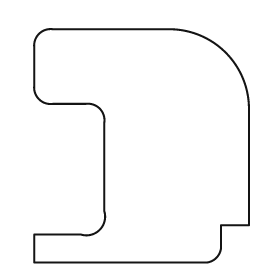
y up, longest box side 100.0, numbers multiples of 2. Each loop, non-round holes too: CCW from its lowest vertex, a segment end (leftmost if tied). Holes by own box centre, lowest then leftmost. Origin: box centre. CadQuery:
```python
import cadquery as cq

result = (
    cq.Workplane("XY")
    .moveTo(-46.0, -50.0)
    .lineTo(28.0, -50.0)
    .threePointArc((32.0, -48.0), (34.0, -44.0))
    .lineTo(34.0, -34.0)
    .lineTo(46.0, -34.0)
    .lineTo(46.0, 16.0)
    .threePointArc((36.0, 40.0), (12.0, 50.0))
    .lineTo(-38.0, 50.0)
    .threePointArc((-44.0, 48.0), (-46.0, 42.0))
    .lineTo(-46.0, 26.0)
    .threePointArc((-44.0, 20.0), (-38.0, 18.0))
    .lineTo(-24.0, 18.0)
    .threePointArc((-18.0, 16.0), (-16.0, 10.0))
    .lineTo(-16.0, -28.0)
    .threePointArc((-18.0, -36.0), (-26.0, -38.0))
    .lineTo(-46.0, -38.0)
    .close()
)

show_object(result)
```